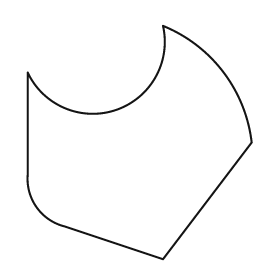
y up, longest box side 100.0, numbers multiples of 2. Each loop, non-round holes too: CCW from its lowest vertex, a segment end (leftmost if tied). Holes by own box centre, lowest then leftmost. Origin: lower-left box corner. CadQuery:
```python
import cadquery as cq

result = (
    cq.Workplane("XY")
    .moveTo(58.0, 0.0)
    .lineTo(96.0, 50.0)
    .threePointArc((84.0, 80.0), (58.0, 100.0))
    .threePointArc((38.0, 64.0), (0.0, 80.0))
    .lineTo(0.0, 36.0)
    .threePointArc((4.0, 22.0), (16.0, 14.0))
    .close()
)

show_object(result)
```